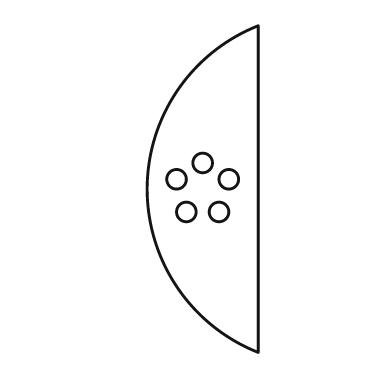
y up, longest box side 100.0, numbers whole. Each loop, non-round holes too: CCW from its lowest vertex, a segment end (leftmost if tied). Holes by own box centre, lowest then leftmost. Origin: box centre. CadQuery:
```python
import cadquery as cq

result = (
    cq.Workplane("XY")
    .moveTo(17.0, -50.0)
    .lineTo(17.0, 50.0)
    .threePointArc((-17.0, 0.0), (17.0, -50.0))
    .close()
    .moveTo(-5.0, -7.0)
    .circle(3.0)
    .moveTo(5.0, -7.0)
    .circle(3.0)
    .moveTo(-8.0, 3.0)
    .circle(3.0)
    .moveTo(8.0, 3.0)
    .circle(3.0)
    .moveTo(0.0, 8.0)
    .circle(3.0)
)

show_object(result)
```